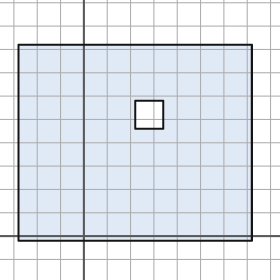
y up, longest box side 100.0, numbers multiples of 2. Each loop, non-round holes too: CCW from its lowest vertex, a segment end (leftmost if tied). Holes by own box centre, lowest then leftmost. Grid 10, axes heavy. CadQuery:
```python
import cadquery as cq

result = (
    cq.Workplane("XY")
    .moveTo(-28.0, -2.0)
    .lineTo(72.0, -2.0)
    .lineTo(72.0, 82.0)
    .lineTo(-28.0, 82.0)
    .close()
    .moveTo(22.0, 46.0)
    .lineTo(34.0, 46.0)
    .lineTo(34.0, 58.0)
    .lineTo(22.0, 58.0)
    .close()
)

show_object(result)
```